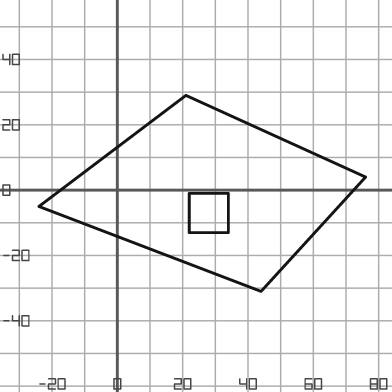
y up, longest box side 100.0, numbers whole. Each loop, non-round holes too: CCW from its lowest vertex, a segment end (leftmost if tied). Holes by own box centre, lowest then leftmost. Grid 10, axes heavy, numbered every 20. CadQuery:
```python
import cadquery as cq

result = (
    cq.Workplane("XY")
    .moveTo(44.0, -31.0)
    .lineTo(76.0, 4.0)
    .lineTo(21.0, 29.0)
    .lineTo(-24.0, -5.0)
    .close()
    .moveTo(22.0, -13.0)
    .lineTo(34.0, -13.0)
    .lineTo(34.0, -1.0)
    .lineTo(22.0, -1.0)
    .close()
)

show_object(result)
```